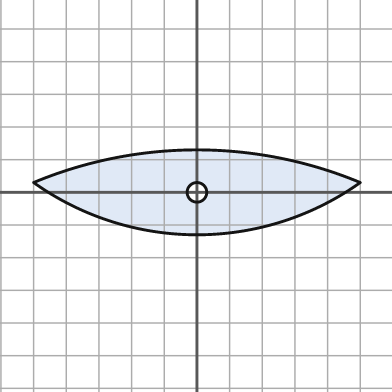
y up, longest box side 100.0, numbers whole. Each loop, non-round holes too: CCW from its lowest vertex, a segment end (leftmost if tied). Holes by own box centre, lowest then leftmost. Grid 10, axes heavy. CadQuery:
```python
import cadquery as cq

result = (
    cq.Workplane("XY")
    .moveTo(-50.0, 3.0)
    .threePointArc((0.0, -13.0), (50.0, 3.0))
    .threePointArc((0.0, 13.0), (-50.0, 3.0))
    .close()
    .moveTo(0.0, 0.0)
    .circle(3.0)
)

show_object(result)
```